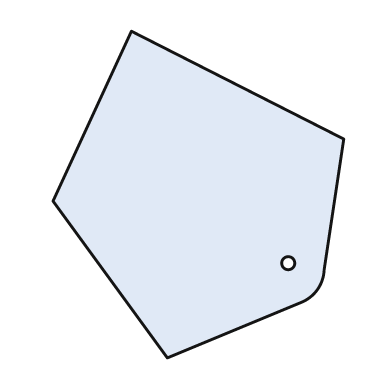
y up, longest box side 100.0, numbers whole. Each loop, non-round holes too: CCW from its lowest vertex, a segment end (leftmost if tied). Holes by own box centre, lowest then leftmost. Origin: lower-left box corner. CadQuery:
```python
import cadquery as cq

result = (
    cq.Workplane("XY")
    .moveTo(35.0, 0.0)
    .lineTo(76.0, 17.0)
    .threePointArc((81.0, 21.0), (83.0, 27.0))
    .lineTo(89.0, 67.0)
    .lineTo(24.0, 100.0)
    .lineTo(0.0, 48.0)
    .close()
    .moveTo(72.0, 29.0)
    .circle(2.0)
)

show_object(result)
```